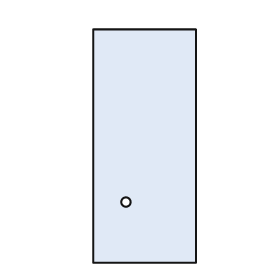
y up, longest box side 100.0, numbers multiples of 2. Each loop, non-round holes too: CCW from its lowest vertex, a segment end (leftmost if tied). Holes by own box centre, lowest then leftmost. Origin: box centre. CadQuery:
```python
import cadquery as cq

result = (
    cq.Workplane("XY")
    .moveTo(-22.0, -50.0)
    .lineTo(22.0, -50.0)
    .lineTo(22.0, 50.0)
    .lineTo(-22.0, 50.0)
    .close()
    .moveTo(-8.0, -24.0)
    .circle(2.0)
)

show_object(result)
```